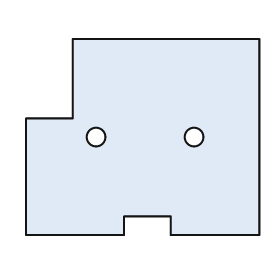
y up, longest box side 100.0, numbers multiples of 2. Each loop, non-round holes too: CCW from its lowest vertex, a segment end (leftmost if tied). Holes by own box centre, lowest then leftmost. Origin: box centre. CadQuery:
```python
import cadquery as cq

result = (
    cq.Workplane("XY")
    .moveTo(-50.0, -42.0)
    .lineTo(-8.0, -42.0)
    .lineTo(-8.0, -34.0)
    .lineTo(12.0, -34.0)
    .lineTo(12.0, -42.0)
    .lineTo(50.0, -42.0)
    .lineTo(50.0, 42.0)
    .lineTo(-30.0, 42.0)
    .lineTo(-30.0, 8.0)
    .lineTo(-50.0, 8.0)
    .close()
    .moveTo(-20.0, 0.0)
    .circle(4.0)
    .moveTo(22.0, 0.0)
    .circle(4.0)
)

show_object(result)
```